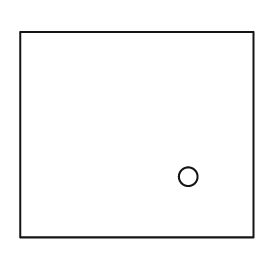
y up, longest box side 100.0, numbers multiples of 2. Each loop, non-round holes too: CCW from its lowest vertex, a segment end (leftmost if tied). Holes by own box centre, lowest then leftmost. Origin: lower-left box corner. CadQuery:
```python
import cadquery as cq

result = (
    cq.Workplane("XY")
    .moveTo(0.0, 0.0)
    .lineTo(100.0, 0.0)
    .lineTo(100.0, 88.0)
    .lineTo(0.0, 88.0)
    .close()
    .moveTo(72.0, 26.0)
    .circle(4.0)
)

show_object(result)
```